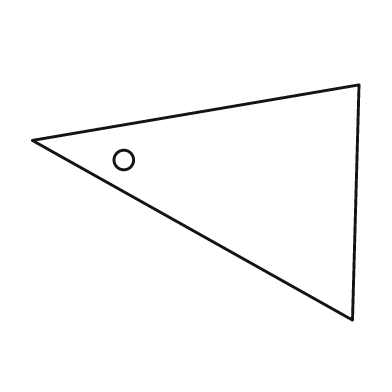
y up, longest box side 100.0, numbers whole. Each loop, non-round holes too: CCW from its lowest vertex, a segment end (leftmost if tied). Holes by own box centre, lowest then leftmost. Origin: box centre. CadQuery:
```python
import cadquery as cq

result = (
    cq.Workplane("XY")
    .moveTo(48.0, -36.0)
    .lineTo(50.0, 36.0)
    .lineTo(-50.0, 19.0)
    .close()
    .moveTo(-22.0, 13.0)
    .circle(3.0)
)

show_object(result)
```